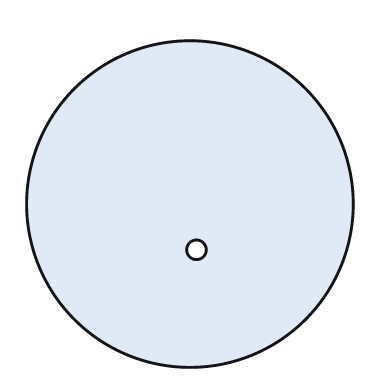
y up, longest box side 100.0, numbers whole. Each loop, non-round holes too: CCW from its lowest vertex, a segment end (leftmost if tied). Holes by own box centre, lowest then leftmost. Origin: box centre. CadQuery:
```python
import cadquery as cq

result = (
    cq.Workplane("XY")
    .moveTo(0.0, 0.0)
    .circle(50.0)
    .moveTo(2.0, -14.0)
    .circle(3.0)
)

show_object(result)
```